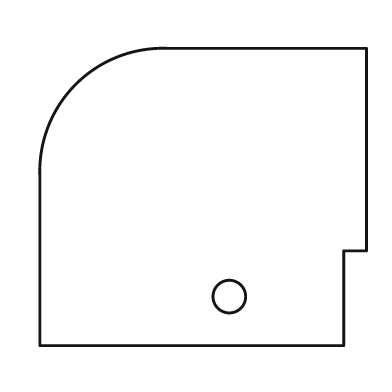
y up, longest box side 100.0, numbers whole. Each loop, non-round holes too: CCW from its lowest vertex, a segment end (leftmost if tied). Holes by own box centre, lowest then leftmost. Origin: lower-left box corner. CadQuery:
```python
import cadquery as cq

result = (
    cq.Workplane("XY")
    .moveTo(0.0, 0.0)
    .lineTo(93.0, 0.0)
    .lineTo(93.0, 29.0)
    .lineTo(100.0, 29.0)
    .lineTo(100.0, 91.0)
    .lineTo(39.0, 91.0)
    .threePointArc((11.0, 80.0), (0.0, 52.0))
    .close()
    .moveTo(58.0, 15.0)
    .circle(5.0)
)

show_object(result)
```